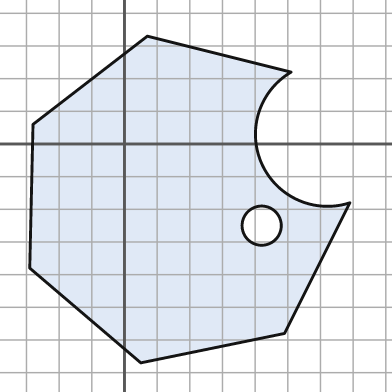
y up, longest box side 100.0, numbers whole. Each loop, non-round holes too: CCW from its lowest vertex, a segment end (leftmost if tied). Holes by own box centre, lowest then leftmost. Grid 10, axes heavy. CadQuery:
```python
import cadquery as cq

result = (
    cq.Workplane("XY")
    .moveTo(5.0, -67.0)
    .lineTo(49.0, -58.0)
    .lineTo(69.0, -18.0)
    .threePointArc((42.0, -6.0), (51.0, 22.0))
    .lineTo(7.0, 33.0)
    .lineTo(-28.0, 6.0)
    .lineTo(-29.0, -38.0)
    .close()
    .moveTo(42.0, -25.0)
    .circle(6.0)
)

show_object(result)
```